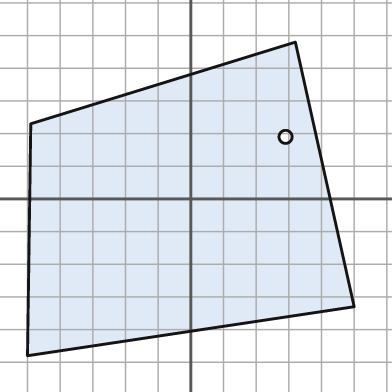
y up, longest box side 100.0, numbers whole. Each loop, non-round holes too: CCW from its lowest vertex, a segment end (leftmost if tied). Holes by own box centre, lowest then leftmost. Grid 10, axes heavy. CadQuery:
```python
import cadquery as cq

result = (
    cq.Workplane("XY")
    .moveTo(-50.0, -48.0)
    .lineTo(50.0, -33.0)
    .lineTo(32.0, 48.0)
    .lineTo(-49.0, 23.0)
    .close()
    .moveTo(29.0, 19.0)
    .circle(2.0)
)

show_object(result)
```